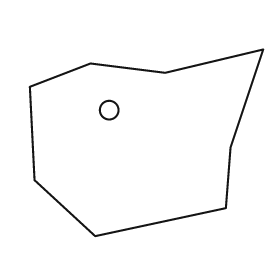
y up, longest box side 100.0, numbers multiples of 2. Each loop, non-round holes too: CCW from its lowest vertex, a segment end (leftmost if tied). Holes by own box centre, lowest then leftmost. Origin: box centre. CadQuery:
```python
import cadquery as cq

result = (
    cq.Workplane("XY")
    .moveTo(-22.0, -40.0)
    .lineTo(34.0, -28.0)
    .lineTo(36.0, -2.0)
    .lineTo(50.0, 40.0)
    .lineTo(8.0, 30.0)
    .lineTo(-24.0, 34.0)
    .lineTo(-50.0, 24.0)
    .lineTo(-48.0, -16.0)
    .close()
    .moveTo(-16.0, 14.0)
    .circle(4.0)
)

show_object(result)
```